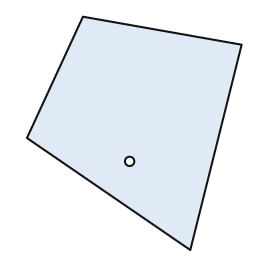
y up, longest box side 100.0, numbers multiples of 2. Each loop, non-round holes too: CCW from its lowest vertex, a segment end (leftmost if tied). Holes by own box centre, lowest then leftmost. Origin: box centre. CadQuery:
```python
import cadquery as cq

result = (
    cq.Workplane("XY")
    .moveTo(24.0, -50.0)
    .lineTo(46.0, 38.0)
    .lineTo(-22.0, 50.0)
    .lineTo(-46.0, -2.0)
    .close()
    .moveTo(-2.0, -12.0)
    .circle(2.0)
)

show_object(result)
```